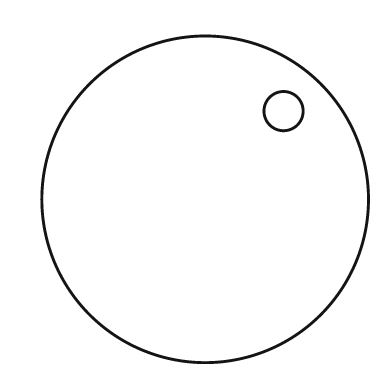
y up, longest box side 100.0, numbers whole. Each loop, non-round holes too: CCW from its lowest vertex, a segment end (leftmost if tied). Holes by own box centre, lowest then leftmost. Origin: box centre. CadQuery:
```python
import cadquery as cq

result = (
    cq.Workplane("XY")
    .moveTo(0.0, 0.0)
    .circle(50.0)
    .moveTo(24.0, 27.0)
    .circle(6.0)
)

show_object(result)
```